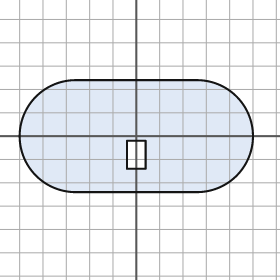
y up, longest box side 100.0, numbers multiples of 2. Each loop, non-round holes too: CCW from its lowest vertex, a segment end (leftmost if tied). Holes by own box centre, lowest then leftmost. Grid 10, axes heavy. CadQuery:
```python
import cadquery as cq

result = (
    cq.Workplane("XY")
    .moveTo(-26.0, -24.0)
    .lineTo(26.0, -24.0)
    .threePointArc((50.0, 0.0), (26.0, 24.0))
    .lineTo(-26.0, 24.0)
    .threePointArc((-50.0, 0.0), (-26.0, -24.0))
    .close()
    .moveTo(-4.0, -14.0)
    .lineTo(4.0, -14.0)
    .lineTo(4.0, -2.0)
    .lineTo(-4.0, -2.0)
    .close()
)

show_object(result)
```